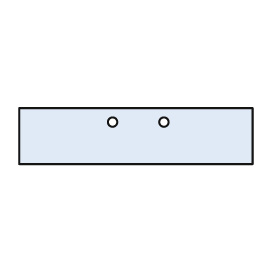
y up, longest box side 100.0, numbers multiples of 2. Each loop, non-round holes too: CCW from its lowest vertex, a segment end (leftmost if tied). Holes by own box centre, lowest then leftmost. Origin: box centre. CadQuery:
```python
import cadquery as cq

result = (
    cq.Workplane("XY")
    .moveTo(-50.0, -12.0)
    .lineTo(50.0, -12.0)
    .lineTo(50.0, 12.0)
    .lineTo(-50.0, 12.0)
    .close()
    .moveTo(-10.0, 6.0)
    .circle(2.0)
    .moveTo(12.0, 6.0)
    .circle(2.0)
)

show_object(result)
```